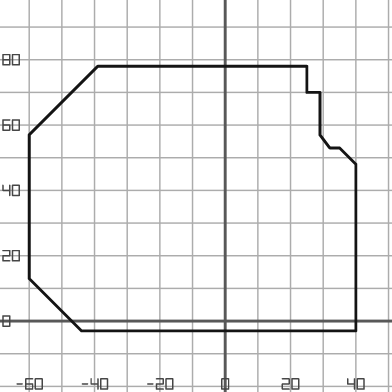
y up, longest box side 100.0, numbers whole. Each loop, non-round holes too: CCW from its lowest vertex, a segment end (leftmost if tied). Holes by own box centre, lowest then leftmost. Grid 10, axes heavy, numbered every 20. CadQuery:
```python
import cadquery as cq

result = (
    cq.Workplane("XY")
    .moveTo(-44.0, -3.0)
    .lineTo(40.0, -3.0)
    .lineTo(40.0, 48.0)
    .lineTo(35.0, 53.0)
    .lineTo(32.0, 53.0)
    .lineTo(29.0, 57.0)
    .lineTo(29.0, 70.0)
    .lineTo(25.0, 70.0)
    .lineTo(25.0, 78.0)
    .lineTo(-39.0, 78.0)
    .lineTo(-60.0, 57.0)
    .lineTo(-60.0, 13.0)
    .close()
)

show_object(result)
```